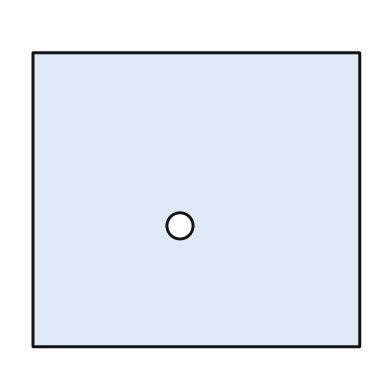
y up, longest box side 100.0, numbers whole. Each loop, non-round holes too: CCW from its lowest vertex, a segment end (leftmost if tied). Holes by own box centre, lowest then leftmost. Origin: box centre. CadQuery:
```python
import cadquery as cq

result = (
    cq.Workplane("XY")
    .moveTo(-50.0, -45.0)
    .lineTo(50.0, -45.0)
    .lineTo(50.0, 45.0)
    .lineTo(-50.0, 45.0)
    .close()
    .moveTo(-5.0, -8.0)
    .circle(4.0)
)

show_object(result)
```